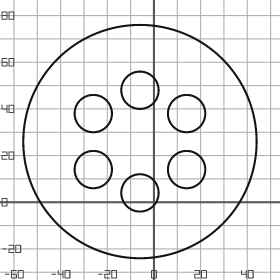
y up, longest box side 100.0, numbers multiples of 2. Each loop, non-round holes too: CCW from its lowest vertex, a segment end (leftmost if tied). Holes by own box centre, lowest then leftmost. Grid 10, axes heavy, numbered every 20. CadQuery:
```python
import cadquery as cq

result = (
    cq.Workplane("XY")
    .moveTo(-6.0, 26.0)
    .circle(50.0)
    .moveTo(-6.0, 4.0)
    .circle(8.0)
    .moveTo(-26.0, 14.0)
    .circle(8.0)
    .moveTo(14.0, 14.0)
    .circle(8.0)
    .moveTo(-26.0, 38.0)
    .circle(8.0)
    .moveTo(14.0, 38.0)
    .circle(8.0)
    .moveTo(-6.0, 48.0)
    .circle(8.0)
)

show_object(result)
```